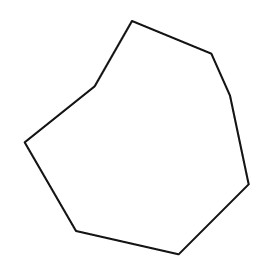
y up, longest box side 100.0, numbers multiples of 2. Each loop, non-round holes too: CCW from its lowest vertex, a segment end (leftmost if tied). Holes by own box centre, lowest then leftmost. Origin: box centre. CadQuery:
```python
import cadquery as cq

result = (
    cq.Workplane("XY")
    .moveTo(18.0, -50.0)
    .lineTo(48.0, -20.0)
    .lineTo(40.0, 18.0)
    .lineTo(32.0, 36.0)
    .lineTo(-2.0, 50.0)
    .lineTo(-18.0, 22.0)
    .lineTo(-48.0, -2.0)
    .lineTo(-26.0, -40.0)
    .close()
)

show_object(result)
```